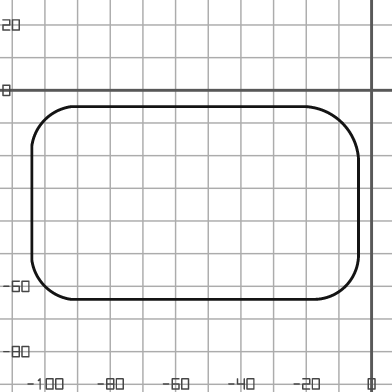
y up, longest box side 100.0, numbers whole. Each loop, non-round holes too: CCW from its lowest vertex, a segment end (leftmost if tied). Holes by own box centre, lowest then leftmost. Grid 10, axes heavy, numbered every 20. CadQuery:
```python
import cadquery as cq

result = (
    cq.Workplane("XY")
    .moveTo(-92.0, -64.0)
    .lineTo(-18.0, -64.0)
    .threePointArc((-8.0, -60.0), (-4.0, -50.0))
    .lineTo(-4.0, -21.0)
    .threePointArc((-9.0, -10.0), (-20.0, -5.0))
    .lineTo(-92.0, -5.0)
    .threePointArc((-100.0, -9.0), (-104.0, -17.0))
    .lineTo(-104.0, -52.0)
    .threePointArc((-100.0, -60.0), (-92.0, -64.0))
    .close()
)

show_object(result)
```